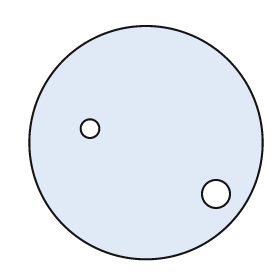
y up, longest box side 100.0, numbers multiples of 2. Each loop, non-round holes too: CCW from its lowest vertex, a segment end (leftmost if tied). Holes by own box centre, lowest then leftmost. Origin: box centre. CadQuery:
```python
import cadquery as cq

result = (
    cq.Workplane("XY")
    .moveTo(0.0, 0.0)
    .circle(50.0)
    .moveTo(30.0, -22.0)
    .circle(6.0)
    .moveTo(-24.0, 6.0)
    .circle(4.0)
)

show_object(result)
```